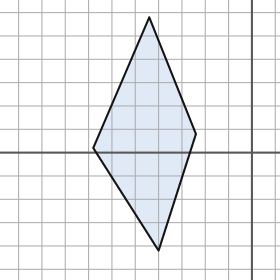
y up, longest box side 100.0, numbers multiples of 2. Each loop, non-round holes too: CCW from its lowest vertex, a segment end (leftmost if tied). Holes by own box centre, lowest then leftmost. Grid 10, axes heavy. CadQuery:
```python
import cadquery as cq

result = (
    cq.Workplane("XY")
    .moveTo(-40.0, -42.0)
    .lineTo(-24.0, 8.0)
    .lineTo(-44.0, 58.0)
    .lineTo(-68.0, 2.0)
    .close()
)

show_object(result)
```